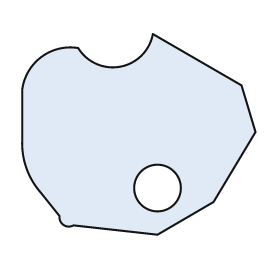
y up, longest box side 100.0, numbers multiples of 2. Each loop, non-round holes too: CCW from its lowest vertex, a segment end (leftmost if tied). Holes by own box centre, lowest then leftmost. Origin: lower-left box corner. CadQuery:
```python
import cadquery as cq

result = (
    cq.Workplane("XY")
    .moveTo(58.0, 0.0)
    .lineTo(82.0, 14.0)
    .lineTo(100.0, 44.0)
    .lineTo(94.0, 64.0)
    .lineTo(56.0, 86.0)
    .threePointArc((42.0, 72.0), (24.0, 80.0))
    .threePointArc((8.0, 76.0), (0.0, 62.0))
    .lineTo(0.0, 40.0)
    .threePointArc((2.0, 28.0), (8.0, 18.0))
    .lineTo(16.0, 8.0)
    .threePointArc((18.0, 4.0), (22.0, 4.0))
    .close()
    .moveTo(58.0, 20.0)
    .circle(10.0)
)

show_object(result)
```